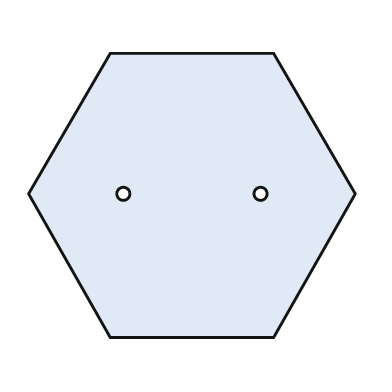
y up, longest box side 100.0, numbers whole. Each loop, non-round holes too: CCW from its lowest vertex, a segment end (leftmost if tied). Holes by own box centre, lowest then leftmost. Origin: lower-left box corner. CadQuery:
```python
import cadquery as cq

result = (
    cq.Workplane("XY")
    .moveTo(25.0, 0.0)
    .lineTo(75.0, 0.0)
    .lineTo(100.0, 44.0)
    .lineTo(75.0, 87.0)
    .lineTo(25.0, 87.0)
    .lineTo(0.0, 44.0)
    .close()
    .moveTo(29.0, 44.0)
    .circle(2.0)
    .moveTo(71.0, 44.0)
    .circle(2.0)
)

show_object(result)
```